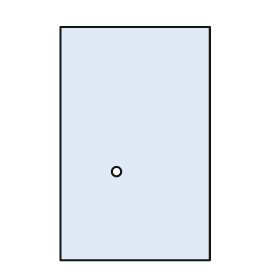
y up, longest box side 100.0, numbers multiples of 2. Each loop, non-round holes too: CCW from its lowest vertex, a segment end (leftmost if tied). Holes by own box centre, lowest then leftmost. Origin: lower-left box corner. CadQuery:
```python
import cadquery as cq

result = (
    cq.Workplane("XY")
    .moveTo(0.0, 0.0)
    .lineTo(64.0, 0.0)
    .lineTo(64.0, 100.0)
    .lineTo(0.0, 100.0)
    .close()
    .moveTo(24.0, 38.0)
    .circle(2.0)
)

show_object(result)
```